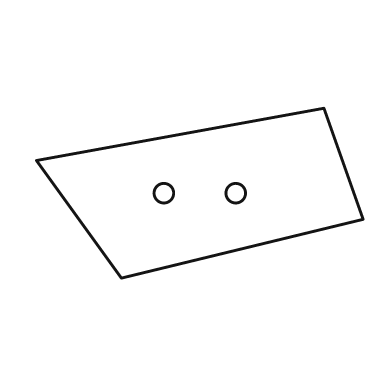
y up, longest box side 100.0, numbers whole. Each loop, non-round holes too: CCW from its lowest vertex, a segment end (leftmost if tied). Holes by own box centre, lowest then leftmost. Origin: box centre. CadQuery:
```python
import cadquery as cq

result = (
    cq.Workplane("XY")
    .moveTo(-24.0, -26.0)
    .lineTo(50.0, -8.0)
    .lineTo(38.0, 26.0)
    .lineTo(-50.0, 10.0)
    .close()
    .moveTo(-11.0, 0.0)
    .circle(3.0)
    .moveTo(11.0, 0.0)
    .circle(3.0)
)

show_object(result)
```